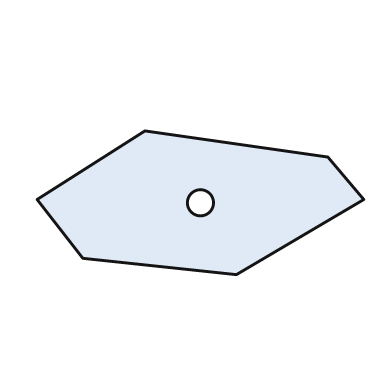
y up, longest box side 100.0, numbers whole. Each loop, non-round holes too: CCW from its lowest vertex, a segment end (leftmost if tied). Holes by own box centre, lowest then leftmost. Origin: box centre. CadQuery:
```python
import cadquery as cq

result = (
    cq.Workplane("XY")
    .moveTo(11.0, -22.0)
    .lineTo(50.0, 1.0)
    .lineTo(39.0, 14.0)
    .lineTo(-17.0, 22.0)
    .lineTo(-50.0, 1.0)
    .lineTo(-36.0, -17.0)
    .close()
    .moveTo(0.0, 0.0)
    .circle(4.0)
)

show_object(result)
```